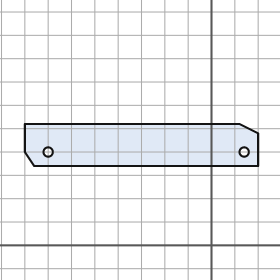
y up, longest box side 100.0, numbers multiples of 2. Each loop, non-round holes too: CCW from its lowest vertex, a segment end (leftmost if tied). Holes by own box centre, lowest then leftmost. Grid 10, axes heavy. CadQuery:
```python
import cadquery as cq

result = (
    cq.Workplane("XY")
    .moveTo(-76.0, 34.0)
    .lineTo(20.0, 34.0)
    .lineTo(20.0, 48.0)
    .lineTo(12.0, 52.0)
    .lineTo(-80.0, 52.0)
    .lineTo(-80.0, 40.0)
    .close()
    .moveTo(-70.0, 40.0)
    .circle(2.0)
    .moveTo(14.0, 40.0)
    .circle(2.0)
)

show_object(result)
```